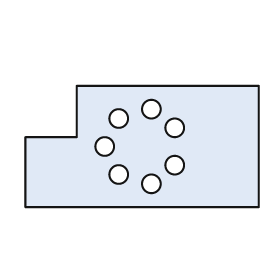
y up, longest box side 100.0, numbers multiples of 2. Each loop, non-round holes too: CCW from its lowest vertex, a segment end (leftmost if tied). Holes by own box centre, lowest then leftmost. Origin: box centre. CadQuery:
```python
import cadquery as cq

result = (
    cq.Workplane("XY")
    .moveTo(-50.0, -26.0)
    .lineTo(50.0, -26.0)
    .lineTo(50.0, 26.0)
    .lineTo(-28.0, 26.0)
    .lineTo(-28.0, 4.0)
    .lineTo(-50.0, 4.0)
    .close()
    .moveTo(4.0, -16.0)
    .circle(4.0)
    .moveTo(-10.0, -12.0)
    .circle(4.0)
    .moveTo(14.0, -8.0)
    .circle(4.0)
    .moveTo(-16.0, 0.0)
    .circle(4.0)
    .moveTo(14.0, 8.0)
    .circle(4.0)
    .moveTo(-10.0, 12.0)
    .circle(4.0)
    .moveTo(4.0, 16.0)
    .circle(4.0)
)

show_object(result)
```